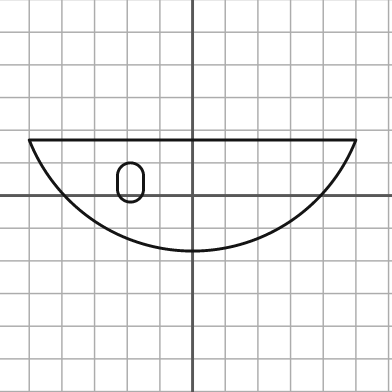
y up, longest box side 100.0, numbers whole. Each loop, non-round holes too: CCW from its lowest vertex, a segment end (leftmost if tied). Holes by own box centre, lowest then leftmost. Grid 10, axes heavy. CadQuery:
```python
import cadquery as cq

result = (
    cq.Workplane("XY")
    .moveTo(-50.0, 17.0)
    .threePointArc((0.0, -17.0), (50.0, 17.0))
    .close()
    .moveTo(-23.0, 2.0)
    .threePointArc((-19.0, -2.0), (-15.0, 2.0))
    .lineTo(-15.0, 6.0)
    .threePointArc((-19.0, 10.0), (-23.0, 6.0))
    .close()
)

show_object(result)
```